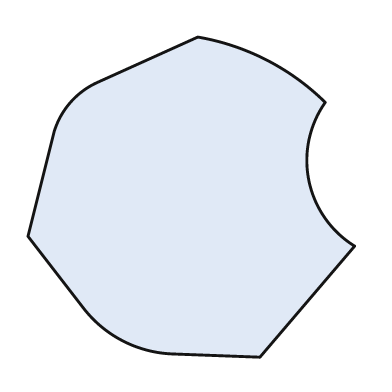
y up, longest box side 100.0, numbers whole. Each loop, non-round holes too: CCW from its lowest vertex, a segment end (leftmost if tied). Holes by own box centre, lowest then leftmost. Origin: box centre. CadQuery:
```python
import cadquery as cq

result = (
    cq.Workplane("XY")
    .moveTo(21.0, -49.0)
    .lineTo(50.0, -15.0)
    .threePointArc((36.0, 5.0), (41.0, 29.0))
    .threePointArc((23.0, 42.0), (2.0, 49.0))
    .lineTo(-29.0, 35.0)
    .threePointArc((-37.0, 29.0), (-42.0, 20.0))
    .lineTo(-50.0, -12.0)
    .lineTo(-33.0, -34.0)
    .threePointArc((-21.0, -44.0), (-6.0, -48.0))
    .close()
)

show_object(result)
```